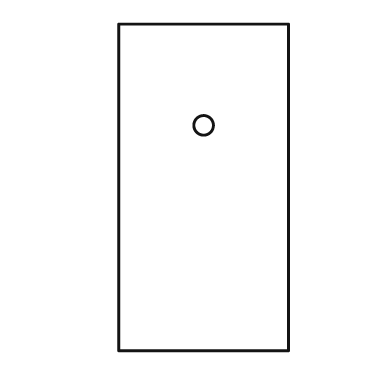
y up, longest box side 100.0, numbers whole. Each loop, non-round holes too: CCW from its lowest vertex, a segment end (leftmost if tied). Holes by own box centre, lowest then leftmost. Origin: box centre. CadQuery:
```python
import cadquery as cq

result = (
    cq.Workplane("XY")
    .moveTo(-26.0, -50.0)
    .lineTo(26.0, -50.0)
    .lineTo(26.0, 50.0)
    .lineTo(-26.0, 50.0)
    .close()
    .moveTo(0.0, 19.0)
    .circle(3.0)
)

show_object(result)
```